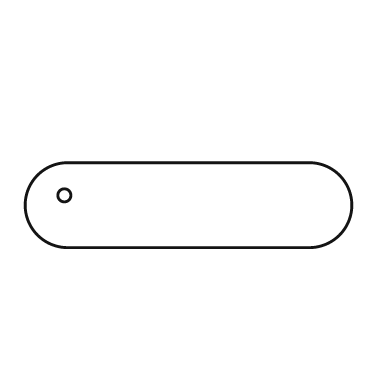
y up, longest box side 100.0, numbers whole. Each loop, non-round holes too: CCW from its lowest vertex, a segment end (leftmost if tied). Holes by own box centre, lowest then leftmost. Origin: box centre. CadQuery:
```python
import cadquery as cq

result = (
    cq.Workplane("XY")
    .moveTo(-37.0, -13.0)
    .lineTo(37.0, -13.0)
    .threePointArc((50.0, 0.0), (37.0, 13.0))
    .lineTo(-37.0, 13.0)
    .threePointArc((-50.0, 0.0), (-37.0, -13.0))
    .close()
    .moveTo(-38.0, 3.0)
    .circle(2.0)
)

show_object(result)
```